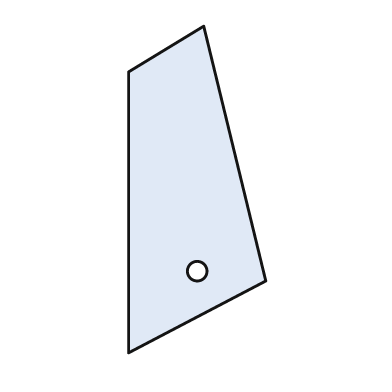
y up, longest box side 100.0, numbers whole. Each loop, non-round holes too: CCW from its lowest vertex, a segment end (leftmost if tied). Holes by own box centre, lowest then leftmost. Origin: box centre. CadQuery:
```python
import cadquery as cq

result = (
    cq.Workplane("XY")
    .moveTo(-21.0, -50.0)
    .lineTo(21.0, -28.0)
    .lineTo(2.0, 50.0)
    .lineTo(-21.0, 36.0)
    .close()
    .moveTo(0.0, -25.0)
    .circle(3.0)
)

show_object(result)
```